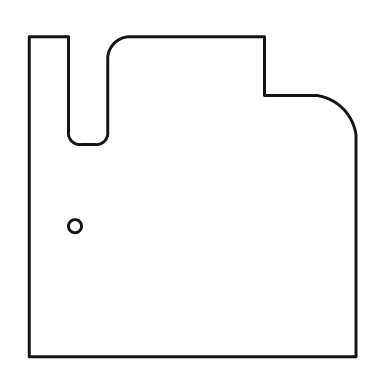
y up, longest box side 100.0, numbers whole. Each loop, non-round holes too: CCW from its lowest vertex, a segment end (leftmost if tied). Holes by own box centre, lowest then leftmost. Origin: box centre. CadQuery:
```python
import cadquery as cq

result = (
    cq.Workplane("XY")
    .moveTo(-50.0, -49.0)
    .lineTo(50.0, -49.0)
    .lineTo(50.0, 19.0)
    .threePointArc((46.0, 27.0), (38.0, 31.0))
    .lineTo(22.0, 31.0)
    .lineTo(22.0, 49.0)
    .lineTo(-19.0, 49.0)
    .threePointArc((-24.0, 47.0), (-26.0, 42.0))
    .lineTo(-26.0, 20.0)
    .threePointArc((-27.0, 17.0), (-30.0, 16.0))
    .lineTo(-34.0, 16.0)
    .threePointArc((-37.0, 17.0), (-38.0, 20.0))
    .lineTo(-38.0, 49.0)
    .lineTo(-50.0, 49.0)
    .close()
    .moveTo(-36.0, -9.0)
    .circle(2.0)
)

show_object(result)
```